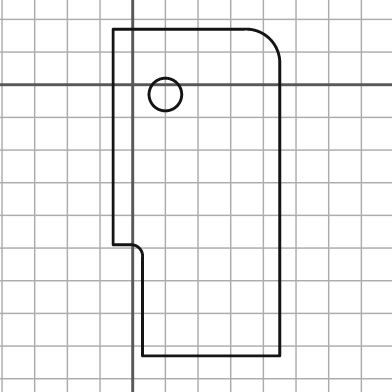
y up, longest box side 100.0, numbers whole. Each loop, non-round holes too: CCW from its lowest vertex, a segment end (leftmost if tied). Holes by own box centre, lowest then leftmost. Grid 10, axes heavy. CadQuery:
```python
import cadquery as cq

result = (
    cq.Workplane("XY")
    .moveTo(3.0, -83.0)
    .lineTo(45.0, -83.0)
    .lineTo(45.0, 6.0)
    .threePointArc((42.0, 14.0), (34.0, 17.0))
    .lineTo(-6.0, 17.0)
    .lineTo(-6.0, -49.0)
    .lineTo(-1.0, -49.0)
    .threePointArc((2.0, -50.0), (3.0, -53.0))
    .close()
    .moveTo(10.0, -3.0)
    .circle(5.0)
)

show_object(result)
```